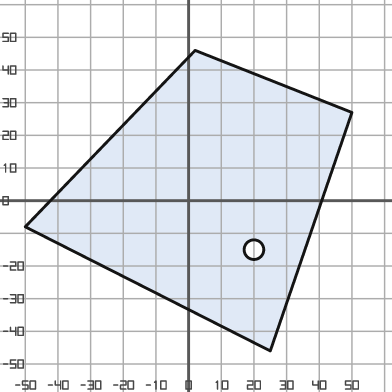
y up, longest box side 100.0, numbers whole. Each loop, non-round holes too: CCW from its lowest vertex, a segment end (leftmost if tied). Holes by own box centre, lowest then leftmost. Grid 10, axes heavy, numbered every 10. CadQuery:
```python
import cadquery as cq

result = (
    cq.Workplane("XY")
    .moveTo(25.0, -46.0)
    .lineTo(50.0, 27.0)
    .lineTo(2.0, 46.0)
    .lineTo(-50.0, -8.0)
    .close()
    .moveTo(20.0, -15.0)
    .circle(3.0)
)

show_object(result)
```